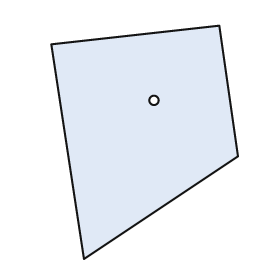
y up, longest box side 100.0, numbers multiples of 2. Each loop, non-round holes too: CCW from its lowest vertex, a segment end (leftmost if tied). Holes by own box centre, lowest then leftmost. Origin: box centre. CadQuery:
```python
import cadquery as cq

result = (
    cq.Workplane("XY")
    .moveTo(-26.0, -50.0)
    .lineTo(40.0, -6.0)
    .lineTo(32.0, 50.0)
    .lineTo(-40.0, 42.0)
    .close()
    .moveTo(4.0, 18.0)
    .circle(2.0)
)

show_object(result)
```